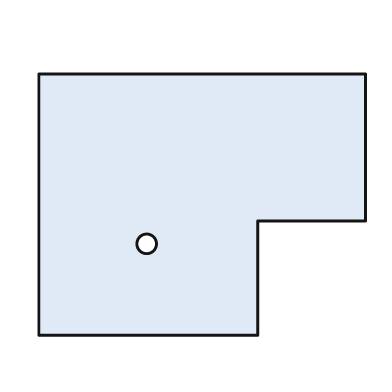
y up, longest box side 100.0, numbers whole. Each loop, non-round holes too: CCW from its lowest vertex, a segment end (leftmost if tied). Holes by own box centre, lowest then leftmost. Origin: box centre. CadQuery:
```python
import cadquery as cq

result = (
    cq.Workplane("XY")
    .moveTo(-50.0, -40.0)
    .lineTo(17.0, -40.0)
    .lineTo(17.0, -5.0)
    .lineTo(50.0, -5.0)
    .lineTo(50.0, 40.0)
    .lineTo(-50.0, 40.0)
    .close()
    .moveTo(-17.0, -12.0)
    .circle(3.0)
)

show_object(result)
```